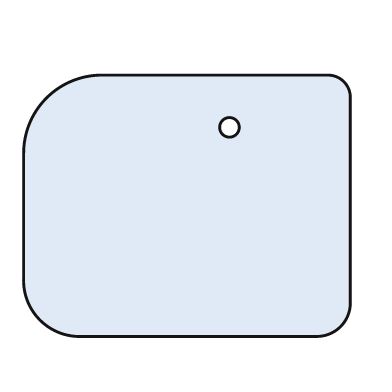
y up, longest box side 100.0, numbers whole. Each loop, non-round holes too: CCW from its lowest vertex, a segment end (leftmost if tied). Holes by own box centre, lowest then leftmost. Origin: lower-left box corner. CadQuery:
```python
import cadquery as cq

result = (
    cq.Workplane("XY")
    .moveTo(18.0, 0.0)
    .lineTo(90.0, 0.0)
    .threePointArc((97.0, 3.0), (100.0, 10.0))
    .lineTo(100.0, 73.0)
    .threePointArc((98.0, 78.0), (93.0, 80.0))
    .lineTo(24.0, 80.0)
    .threePointArc((7.0, 73.0), (0.0, 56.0))
    .lineTo(0.0, 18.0)
    .threePointArc((5.0, 5.0), (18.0, 0.0))
    .close()
    .moveTo(63.0, 64.0)
    .circle(3.0)
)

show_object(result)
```